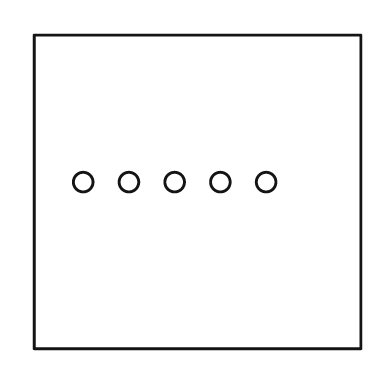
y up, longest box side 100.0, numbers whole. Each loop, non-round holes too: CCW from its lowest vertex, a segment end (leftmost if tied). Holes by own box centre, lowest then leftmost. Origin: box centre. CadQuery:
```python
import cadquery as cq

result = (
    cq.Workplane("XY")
    .moveTo(-50.0, -48.0)
    .lineTo(50.0, -48.0)
    .lineTo(50.0, 48.0)
    .lineTo(-50.0, 48.0)
    .close()
    .moveTo(-35.0, 3.0)
    .circle(3.0)
    .moveTo(-21.0, 3.0)
    .circle(3.0)
    .moveTo(-7.0, 3.0)
    .circle(3.0)
    .moveTo(7.0, 3.0)
    .circle(3.0)
    .moveTo(21.0, 3.0)
    .circle(3.0)
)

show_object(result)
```